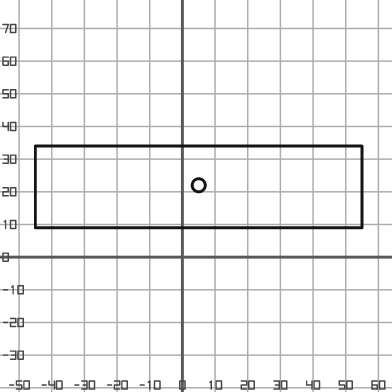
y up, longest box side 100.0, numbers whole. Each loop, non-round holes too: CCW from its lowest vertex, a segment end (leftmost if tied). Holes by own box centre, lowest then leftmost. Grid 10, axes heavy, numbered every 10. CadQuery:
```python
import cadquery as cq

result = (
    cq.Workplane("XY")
    .moveTo(-45.0, 9.0)
    .lineTo(55.0, 9.0)
    .lineTo(55.0, 34.0)
    .lineTo(-45.0, 34.0)
    .close()
    .moveTo(5.0, 22.0)
    .circle(2.0)
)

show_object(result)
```